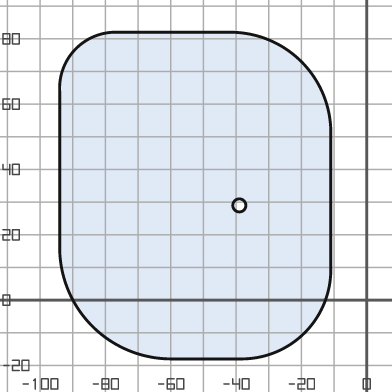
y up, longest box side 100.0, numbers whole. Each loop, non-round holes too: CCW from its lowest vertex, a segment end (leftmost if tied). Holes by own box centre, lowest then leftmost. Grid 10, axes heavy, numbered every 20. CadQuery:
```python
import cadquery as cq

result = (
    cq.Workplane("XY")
    .moveTo(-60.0, -18.0)
    .lineTo(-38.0, -18.0)
    .threePointArc((-19.0, -10.0), (-11.0, 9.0))
    .lineTo(-11.0, 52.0)
    .threePointArc((-20.0, 73.0), (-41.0, 82.0))
    .lineTo(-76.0, 82.0)
    .threePointArc((-89.0, 77.0), (-94.0, 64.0))
    .lineTo(-94.0, 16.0)
    .threePointArc((-84.0, -8.0), (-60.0, -18.0))
    .close()
    .moveTo(-39.0, 29.0)
    .circle(2.0)
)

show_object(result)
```